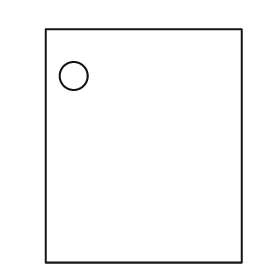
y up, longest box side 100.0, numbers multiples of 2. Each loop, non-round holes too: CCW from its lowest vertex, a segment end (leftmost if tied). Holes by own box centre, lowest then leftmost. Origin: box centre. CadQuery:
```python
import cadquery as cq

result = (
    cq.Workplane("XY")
    .moveTo(-42.0, -50.0)
    .lineTo(42.0, -50.0)
    .lineTo(42.0, 50.0)
    .lineTo(-42.0, 50.0)
    .close()
    .moveTo(-30.0, 30.0)
    .circle(6.0)
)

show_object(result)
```